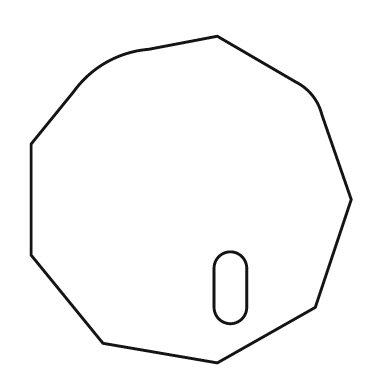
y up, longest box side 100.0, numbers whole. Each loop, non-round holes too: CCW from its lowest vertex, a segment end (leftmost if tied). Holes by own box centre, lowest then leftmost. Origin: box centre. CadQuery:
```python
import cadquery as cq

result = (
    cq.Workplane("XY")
    .moveTo(8.0, -50.0)
    .lineTo(38.0, -33.0)
    .lineTo(49.0, 0.0)
    .lineTo(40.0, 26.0)
    .threePointArc((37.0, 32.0), (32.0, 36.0))
    .lineTo(8.0, 50.0)
    .lineTo(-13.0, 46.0)
    .threePointArc((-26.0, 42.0), (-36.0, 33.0))
    .lineTo(-49.0, 17.0)
    .lineTo(-49.0, -17.0)
    .lineTo(-27.0, -44.0)
    .close()
    .moveTo(7.0, -33.0)
    .threePointArc((12.0, -38.0), (17.0, -33.0))
    .lineTo(17.0, -21.0)
    .threePointArc((12.0, -16.0), (7.0, -21.0))
    .close()
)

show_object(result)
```